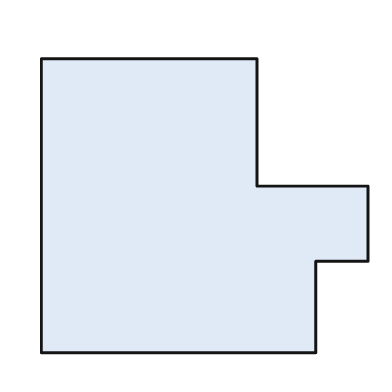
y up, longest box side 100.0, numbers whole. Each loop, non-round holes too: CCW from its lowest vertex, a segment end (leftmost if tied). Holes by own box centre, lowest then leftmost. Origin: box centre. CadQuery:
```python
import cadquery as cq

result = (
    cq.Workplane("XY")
    .moveTo(-50.0, -45.0)
    .lineTo(34.0, -45.0)
    .lineTo(34.0, -17.0)
    .lineTo(50.0, -17.0)
    .lineTo(50.0, 6.0)
    .lineTo(16.0, 6.0)
    .lineTo(16.0, 45.0)
    .lineTo(-50.0, 45.0)
    .close()
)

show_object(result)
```